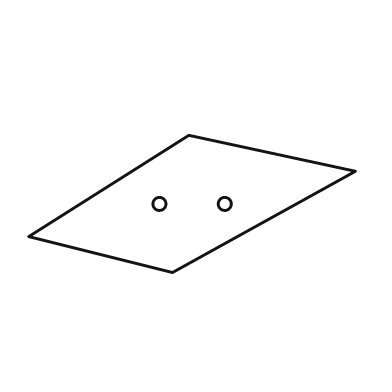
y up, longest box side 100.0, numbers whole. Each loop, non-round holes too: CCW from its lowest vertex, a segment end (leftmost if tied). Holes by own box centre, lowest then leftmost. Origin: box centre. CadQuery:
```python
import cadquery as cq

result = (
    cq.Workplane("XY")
    .moveTo(-6.0, -21.0)
    .lineTo(50.0, 10.0)
    .lineTo(-1.0, 21.0)
    .lineTo(-50.0, -10.0)
    .close()
    .moveTo(-10.0, 0.0)
    .circle(2.0)
    .moveTo(10.0, 0.0)
    .circle(2.0)
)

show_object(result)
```